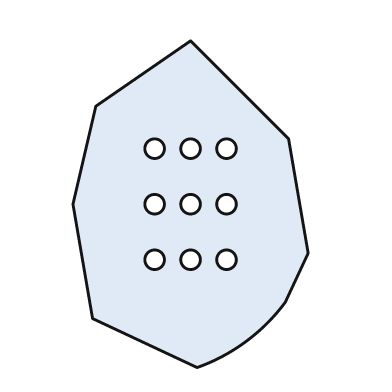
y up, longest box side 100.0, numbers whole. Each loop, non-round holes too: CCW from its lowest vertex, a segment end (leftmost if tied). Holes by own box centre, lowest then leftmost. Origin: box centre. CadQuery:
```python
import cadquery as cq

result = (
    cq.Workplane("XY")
    .moveTo(2.0, -50.0)
    .threePointArc((17.0, -42.0), (29.0, -30.0))
    .lineTo(36.0, -15.0)
    .lineTo(30.0, 20.0)
    .lineTo(0.0, 50.0)
    .lineTo(-29.0, 30.0)
    .lineTo(-36.0, 0.0)
    .lineTo(-30.0, -35.0)
    .close()
    .moveTo(-11.0, -17.0)
    .circle(3.0)
    .moveTo(0.0, -17.0)
    .circle(3.0)
    .moveTo(11.0, -17.0)
    .circle(3.0)
    .moveTo(-11.0, 0.0)
    .circle(3.0)
    .moveTo(0.0, 0.0)
    .circle(3.0)
    .moveTo(11.0, 0.0)
    .circle(3.0)
    .moveTo(-11.0, 17.0)
    .circle(3.0)
    .moveTo(0.0, 17.0)
    .circle(3.0)
    .moveTo(11.0, 17.0)
    .circle(3.0)
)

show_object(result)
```